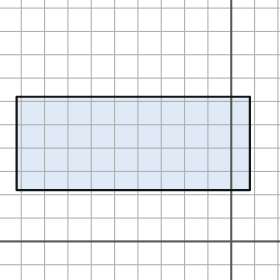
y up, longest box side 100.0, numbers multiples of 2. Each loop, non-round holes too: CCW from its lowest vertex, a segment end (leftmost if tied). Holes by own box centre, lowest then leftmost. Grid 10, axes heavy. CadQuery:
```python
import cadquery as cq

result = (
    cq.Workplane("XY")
    .moveTo(-92.0, 22.0)
    .lineTo(8.0, 22.0)
    .lineTo(8.0, 62.0)
    .lineTo(-92.0, 62.0)
    .close()
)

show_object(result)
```